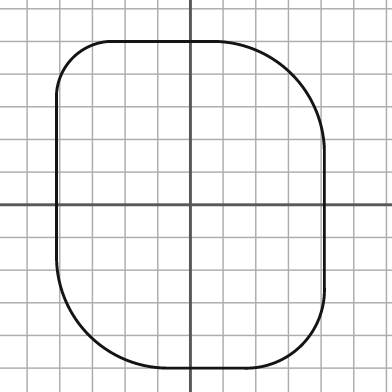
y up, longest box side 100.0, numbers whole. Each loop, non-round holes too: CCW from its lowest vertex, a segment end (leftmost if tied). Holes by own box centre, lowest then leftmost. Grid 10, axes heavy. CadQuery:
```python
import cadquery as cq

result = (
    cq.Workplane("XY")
    .moveTo(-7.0, -50.0)
    .lineTo(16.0, -50.0)
    .threePointArc((34.0, -43.0), (41.0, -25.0))
    .lineTo(41.0, 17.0)
    .threePointArc((31.0, 40.0), (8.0, 50.0))
    .lineTo(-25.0, 50.0)
    .threePointArc((-36.0, 45.0), (-41.0, 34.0))
    .lineTo(-41.0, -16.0)
    .threePointArc((-31.0, -40.0), (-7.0, -50.0))
    .close()
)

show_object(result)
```